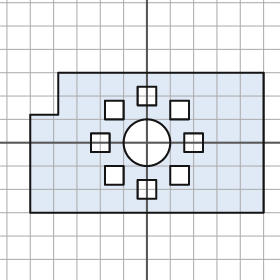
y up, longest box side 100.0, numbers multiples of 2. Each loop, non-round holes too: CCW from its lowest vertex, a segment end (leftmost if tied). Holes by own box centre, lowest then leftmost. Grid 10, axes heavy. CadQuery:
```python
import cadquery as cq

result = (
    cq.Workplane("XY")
    .moveTo(-50.0, -30.0)
    .lineTo(50.0, -30.0)
    .lineTo(50.0, 30.0)
    .lineTo(-38.0, 30.0)
    .lineTo(-38.0, 12.0)
    .lineTo(-50.0, 12.0)
    .close()
    .moveTo(-4.0, -24.0)
    .lineTo(4.0, -24.0)
    .lineTo(4.0, -16.0)
    .lineTo(-4.0, -16.0)
    .close()
    .moveTo(-18.0, -18.0)
    .lineTo(-10.0, -18.0)
    .lineTo(-10.0, -10.0)
    .lineTo(-18.0, -10.0)
    .close()
    .moveTo(10.0, -18.0)
    .lineTo(18.0, -18.0)
    .lineTo(18.0, -10.0)
    .lineTo(10.0, -10.0)
    .close()
    .moveTo(-24.0, -4.0)
    .lineTo(-16.0, -4.0)
    .lineTo(-16.0, 4.0)
    .lineTo(-24.0, 4.0)
    .close()
    .moveTo(0.0, 0.0)
    .circle(10.0)
    .moveTo(16.0, -4.0)
    .lineTo(24.0, -4.0)
    .lineTo(24.0, 4.0)
    .lineTo(16.0, 4.0)
    .close()
    .moveTo(-18.0, 10.0)
    .lineTo(-10.0, 10.0)
    .lineTo(-10.0, 18.0)
    .lineTo(-18.0, 18.0)
    .close()
    .moveTo(10.0, 10.0)
    .lineTo(18.0, 10.0)
    .lineTo(18.0, 18.0)
    .lineTo(10.0, 18.0)
    .close()
    .moveTo(-4.0, 16.0)
    .lineTo(4.0, 16.0)
    .lineTo(4.0, 24.0)
    .lineTo(-4.0, 24.0)
    .close()
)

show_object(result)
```